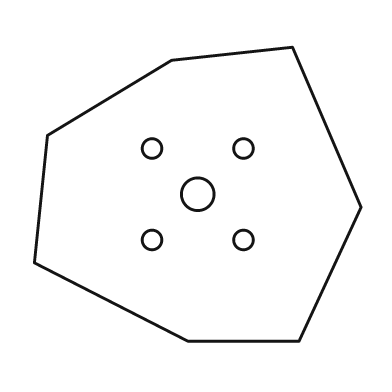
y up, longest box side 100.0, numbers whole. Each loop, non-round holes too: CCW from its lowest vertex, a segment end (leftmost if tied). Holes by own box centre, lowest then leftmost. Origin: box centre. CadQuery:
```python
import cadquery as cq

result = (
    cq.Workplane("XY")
    .moveTo(-3.0, -45.0)
    .lineTo(31.0, -45.0)
    .lineTo(50.0, -4.0)
    .lineTo(29.0, 45.0)
    .lineTo(-8.0, 41.0)
    .lineTo(-46.0, 18.0)
    .lineTo(-50.0, -21.0)
    .close()
    .moveTo(-14.0, -14.0)
    .circle(3.0)
    .moveTo(14.0, -14.0)
    .circle(3.0)
    .moveTo(0.0, 0.0)
    .circle(5.0)
    .moveTo(-14.0, 14.0)
    .circle(3.0)
    .moveTo(14.0, 14.0)
    .circle(3.0)
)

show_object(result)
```